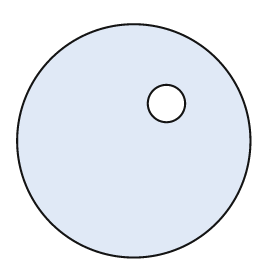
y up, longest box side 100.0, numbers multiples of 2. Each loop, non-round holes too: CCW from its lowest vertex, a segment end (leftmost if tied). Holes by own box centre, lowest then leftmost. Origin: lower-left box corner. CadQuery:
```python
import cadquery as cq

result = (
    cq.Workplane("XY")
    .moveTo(50.0, 50.0)
    .circle(50.0)
    .moveTo(64.0, 66.0)
    .circle(8.0)
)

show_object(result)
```